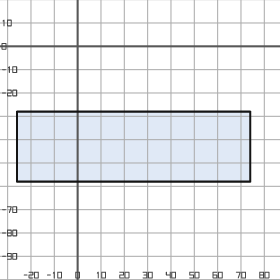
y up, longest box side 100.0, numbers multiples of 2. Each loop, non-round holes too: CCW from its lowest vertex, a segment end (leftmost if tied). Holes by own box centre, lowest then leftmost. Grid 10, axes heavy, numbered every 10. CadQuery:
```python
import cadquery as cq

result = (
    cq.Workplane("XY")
    .moveTo(-26.0, -58.0)
    .lineTo(74.0, -58.0)
    .lineTo(74.0, -28.0)
    .lineTo(-26.0, -28.0)
    .close()
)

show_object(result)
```